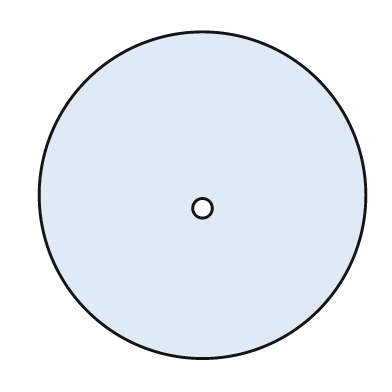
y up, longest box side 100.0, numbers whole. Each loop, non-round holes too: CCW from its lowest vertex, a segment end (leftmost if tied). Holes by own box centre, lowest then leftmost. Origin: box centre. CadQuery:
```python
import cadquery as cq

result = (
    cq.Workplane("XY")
    .moveTo(0.0, 0.0)
    .circle(50.0)
    .moveTo(0.0, -4.0)
    .circle(3.0)
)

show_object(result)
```